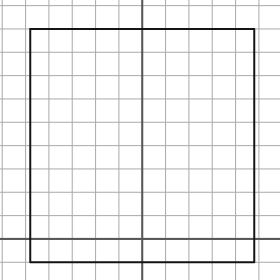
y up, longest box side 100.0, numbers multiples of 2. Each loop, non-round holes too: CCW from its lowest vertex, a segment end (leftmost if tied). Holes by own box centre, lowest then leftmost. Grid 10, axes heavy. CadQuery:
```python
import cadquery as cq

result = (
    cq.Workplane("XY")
    .moveTo(-48.0, -10.0)
    .lineTo(48.0, -10.0)
    .lineTo(48.0, 90.0)
    .lineTo(-48.0, 90.0)
    .close()
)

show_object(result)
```